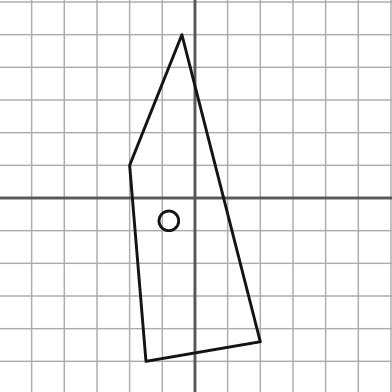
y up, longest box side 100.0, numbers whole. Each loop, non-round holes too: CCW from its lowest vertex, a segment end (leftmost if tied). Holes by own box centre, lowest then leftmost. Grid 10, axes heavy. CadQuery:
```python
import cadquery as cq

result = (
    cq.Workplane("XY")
    .moveTo(-15.0, -50.0)
    .lineTo(20.0, -44.0)
    .lineTo(-4.0, 50.0)
    .lineTo(-20.0, 10.0)
    .close()
    .moveTo(-8.0, -7.0)
    .circle(3.0)
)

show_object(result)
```